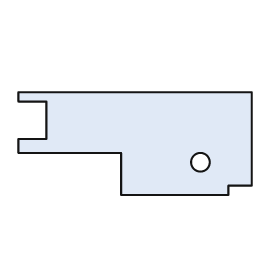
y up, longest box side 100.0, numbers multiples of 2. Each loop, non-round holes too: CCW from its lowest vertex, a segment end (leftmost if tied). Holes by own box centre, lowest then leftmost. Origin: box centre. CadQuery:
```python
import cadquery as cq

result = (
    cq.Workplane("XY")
    .moveTo(-6.0, -22.0)
    .lineTo(40.0, -22.0)
    .lineTo(40.0, -18.0)
    .lineTo(50.0, -18.0)
    .lineTo(50.0, 22.0)
    .lineTo(-50.0, 22.0)
    .lineTo(-50.0, 18.0)
    .lineTo(-38.0, 18.0)
    .lineTo(-38.0, 2.0)
    .lineTo(-50.0, 2.0)
    .lineTo(-50.0, -4.0)
    .lineTo(-6.0, -4.0)
    .close()
    .moveTo(28.0, -8.0)
    .circle(4.0)
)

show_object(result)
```